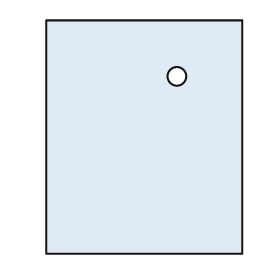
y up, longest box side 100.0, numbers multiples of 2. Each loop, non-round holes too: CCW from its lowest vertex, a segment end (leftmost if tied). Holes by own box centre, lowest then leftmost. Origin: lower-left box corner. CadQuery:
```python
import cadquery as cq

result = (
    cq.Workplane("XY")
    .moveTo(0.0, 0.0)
    .lineTo(84.0, 0.0)
    .lineTo(84.0, 100.0)
    .lineTo(0.0, 100.0)
    .close()
    .moveTo(56.0, 76.0)
    .circle(4.0)
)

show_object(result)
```